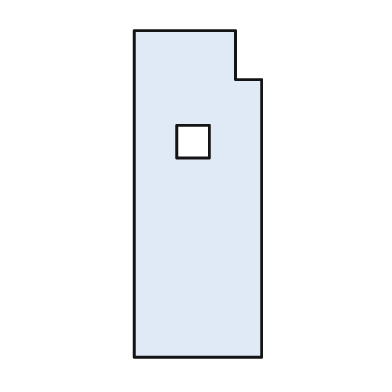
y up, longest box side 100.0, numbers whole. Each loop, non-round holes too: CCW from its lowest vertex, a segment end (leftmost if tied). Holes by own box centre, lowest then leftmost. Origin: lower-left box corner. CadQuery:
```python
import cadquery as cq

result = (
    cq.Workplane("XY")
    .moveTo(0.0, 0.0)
    .lineTo(39.0, 0.0)
    .lineTo(39.0, 85.0)
    .lineTo(31.0, 85.0)
    .lineTo(31.0, 100.0)
    .lineTo(0.0, 100.0)
    .close()
    .moveTo(13.0, 61.0)
    .lineTo(23.0, 61.0)
    .lineTo(23.0, 71.0)
    .lineTo(13.0, 71.0)
    .close()
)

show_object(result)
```